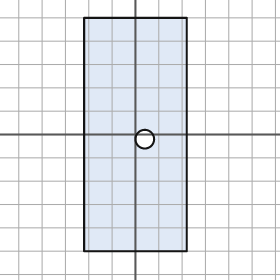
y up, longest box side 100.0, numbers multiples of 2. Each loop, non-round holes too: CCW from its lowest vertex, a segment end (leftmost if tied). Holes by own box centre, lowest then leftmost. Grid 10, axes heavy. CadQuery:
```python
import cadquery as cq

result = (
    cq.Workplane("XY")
    .moveTo(-22.0, -50.0)
    .lineTo(22.0, -50.0)
    .lineTo(22.0, 50.0)
    .lineTo(-22.0, 50.0)
    .close()
    .moveTo(4.0, -2.0)
    .circle(4.0)
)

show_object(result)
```